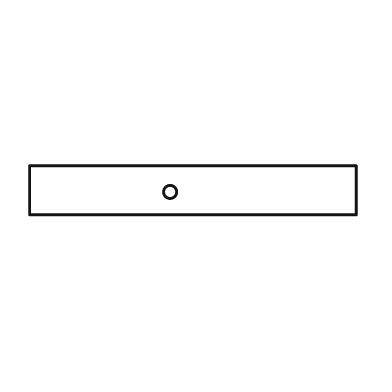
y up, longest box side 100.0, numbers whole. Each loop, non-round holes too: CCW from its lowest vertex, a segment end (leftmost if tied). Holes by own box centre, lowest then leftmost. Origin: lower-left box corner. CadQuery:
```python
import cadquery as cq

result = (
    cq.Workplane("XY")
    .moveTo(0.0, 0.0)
    .lineTo(100.0, 0.0)
    .lineTo(100.0, 15.0)
    .lineTo(0.0, 15.0)
    .close()
    .moveTo(43.0, 7.0)
    .circle(2.0)
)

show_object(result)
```